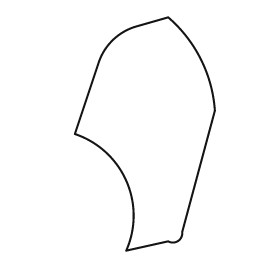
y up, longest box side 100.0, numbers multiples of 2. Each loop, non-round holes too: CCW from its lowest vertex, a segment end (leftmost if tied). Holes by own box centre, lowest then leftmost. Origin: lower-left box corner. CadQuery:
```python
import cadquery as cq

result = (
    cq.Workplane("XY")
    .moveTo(22.0, 0.0)
    .lineTo(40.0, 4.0)
    .threePointArc((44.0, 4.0), (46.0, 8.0))
    .lineTo(60.0, 60.0)
    .threePointArc((54.0, 82.0), (40.0, 100.0))
    .lineTo(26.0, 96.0)
    .threePointArc((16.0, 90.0), (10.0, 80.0))
    .lineTo(0.0, 50.0)
    .threePointArc((22.0, 30.0), (22.0, 0.0))
    .close()
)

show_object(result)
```